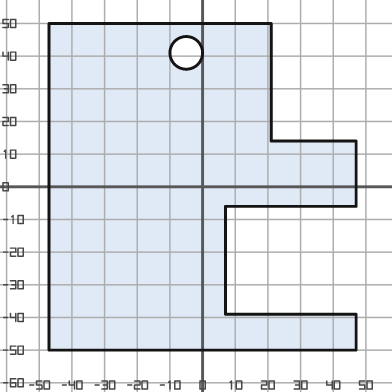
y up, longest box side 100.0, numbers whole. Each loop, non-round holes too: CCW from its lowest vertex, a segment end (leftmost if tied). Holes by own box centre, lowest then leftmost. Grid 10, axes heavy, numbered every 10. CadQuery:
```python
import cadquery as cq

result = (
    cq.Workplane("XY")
    .moveTo(-47.0, -50.0)
    .lineTo(47.0, -50.0)
    .lineTo(47.0, -39.0)
    .lineTo(7.0, -39.0)
    .lineTo(7.0, -6.0)
    .lineTo(47.0, -6.0)
    .lineTo(47.0, 14.0)
    .lineTo(21.0, 14.0)
    .lineTo(21.0, 50.0)
    .lineTo(-47.0, 50.0)
    .close()
    .moveTo(-5.0, 41.0)
    .circle(5.0)
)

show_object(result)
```